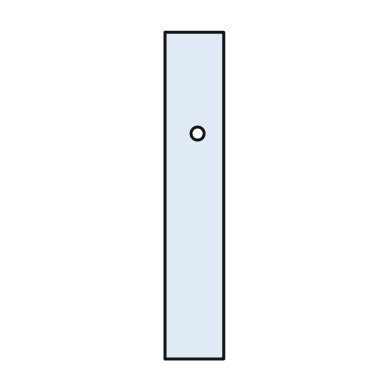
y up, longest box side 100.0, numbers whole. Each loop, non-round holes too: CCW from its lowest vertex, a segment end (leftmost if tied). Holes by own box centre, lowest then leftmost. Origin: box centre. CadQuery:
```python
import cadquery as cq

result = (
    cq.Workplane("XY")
    .moveTo(-9.0, -50.0)
    .lineTo(9.0, -50.0)
    .lineTo(9.0, 50.0)
    .lineTo(-9.0, 50.0)
    .close()
    .moveTo(1.0, 19.0)
    .circle(2.0)
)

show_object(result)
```